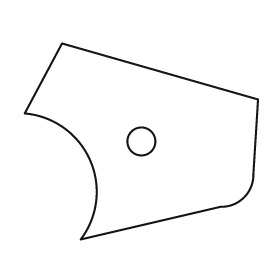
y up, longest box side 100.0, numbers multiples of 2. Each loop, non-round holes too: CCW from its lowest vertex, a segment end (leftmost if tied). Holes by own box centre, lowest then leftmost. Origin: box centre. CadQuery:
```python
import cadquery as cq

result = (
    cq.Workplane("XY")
    .moveTo(-26.0, -42.0)
    .lineTo(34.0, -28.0)
    .threePointArc((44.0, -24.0), (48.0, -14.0))
    .lineTo(50.0, 18.0)
    .lineTo(-34.0, 42.0)
    .lineTo(-50.0, 12.0)
    .threePointArc((-22.0, -8.0), (-26.0, -42.0))
    .close()
    .moveTo(0.0, 0.0)
    .circle(6.0)
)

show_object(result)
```